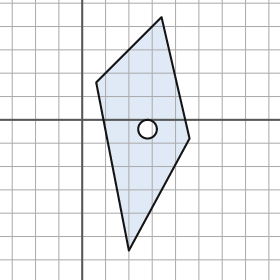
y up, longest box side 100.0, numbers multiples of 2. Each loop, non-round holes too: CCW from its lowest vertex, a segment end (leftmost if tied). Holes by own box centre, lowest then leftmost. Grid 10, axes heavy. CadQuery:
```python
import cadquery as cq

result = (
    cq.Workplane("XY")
    .moveTo(20.0, -56.0)
    .lineTo(46.0, -8.0)
    .lineTo(34.0, 44.0)
    .lineTo(6.0, 16.0)
    .close()
    .moveTo(28.0, -4.0)
    .circle(4.0)
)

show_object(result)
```